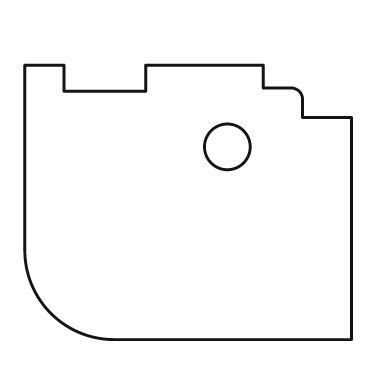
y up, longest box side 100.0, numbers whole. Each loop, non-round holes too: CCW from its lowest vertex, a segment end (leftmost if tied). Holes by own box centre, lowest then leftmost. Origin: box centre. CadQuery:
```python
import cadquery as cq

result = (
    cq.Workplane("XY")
    .moveTo(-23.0, -42.0)
    .lineTo(50.0, -42.0)
    .lineTo(50.0, 26.0)
    .lineTo(35.0, 26.0)
    .lineTo(35.0, 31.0)
    .threePointArc((34.0, 34.0), (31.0, 35.0))
    .lineTo(23.0, 35.0)
    .lineTo(23.0, 42.0)
    .lineTo(-13.0, 42.0)
    .lineTo(-13.0, 34.0)
    .lineTo(-38.0, 34.0)
    .lineTo(-38.0, 42.0)
    .lineTo(-50.0, 42.0)
    .lineTo(-50.0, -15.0)
    .threePointArc((-42.0, -34.0), (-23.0, -42.0))
    .close()
    .moveTo(12.0, 17.0)
    .circle(7.0)
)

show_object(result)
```